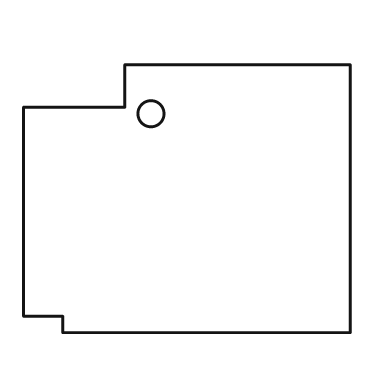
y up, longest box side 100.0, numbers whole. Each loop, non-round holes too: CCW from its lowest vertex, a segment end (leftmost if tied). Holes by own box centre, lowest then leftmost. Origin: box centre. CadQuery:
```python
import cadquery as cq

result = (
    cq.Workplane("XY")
    .moveTo(-38.0, -41.0)
    .lineTo(50.0, -41.0)
    .lineTo(50.0, 41.0)
    .lineTo(-19.0, 41.0)
    .lineTo(-19.0, 28.0)
    .lineTo(-50.0, 28.0)
    .lineTo(-50.0, -36.0)
    .lineTo(-38.0, -36.0)
    .close()
    .moveTo(-11.0, 26.0)
    .circle(4.0)
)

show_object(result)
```